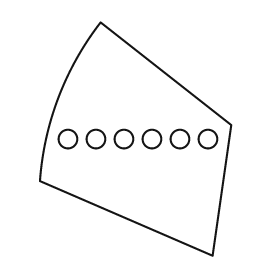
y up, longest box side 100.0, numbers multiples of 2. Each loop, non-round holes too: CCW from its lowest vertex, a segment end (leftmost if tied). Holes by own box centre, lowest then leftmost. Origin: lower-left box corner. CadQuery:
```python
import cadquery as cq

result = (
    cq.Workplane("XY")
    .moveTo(74.0, 0.0)
    .lineTo(82.0, 56.0)
    .lineTo(26.0, 100.0)
    .threePointArc((8.0, 68.0), (0.0, 32.0))
    .close()
    .moveTo(12.0, 50.0)
    .circle(4.0)
    .moveTo(24.0, 50.0)
    .circle(4.0)
    .moveTo(36.0, 50.0)
    .circle(4.0)
    .moveTo(48.0, 50.0)
    .circle(4.0)
    .moveTo(60.0, 50.0)
    .circle(4.0)
    .moveTo(72.0, 50.0)
    .circle(4.0)
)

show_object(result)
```